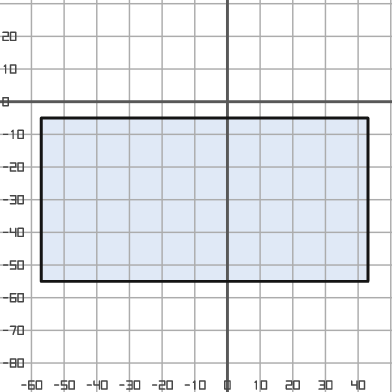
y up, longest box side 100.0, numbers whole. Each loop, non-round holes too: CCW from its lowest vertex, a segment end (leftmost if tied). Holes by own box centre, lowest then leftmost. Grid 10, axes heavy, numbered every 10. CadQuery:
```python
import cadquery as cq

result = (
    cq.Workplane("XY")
    .moveTo(-57.0, -55.0)
    .lineTo(43.0, -55.0)
    .lineTo(43.0, -5.0)
    .lineTo(-57.0, -5.0)
    .close()
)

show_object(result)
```